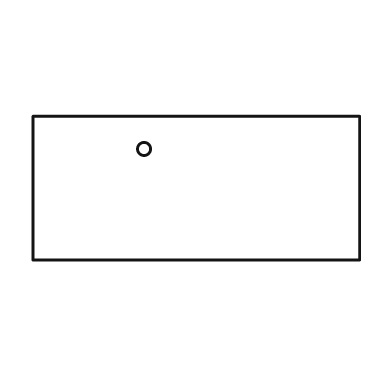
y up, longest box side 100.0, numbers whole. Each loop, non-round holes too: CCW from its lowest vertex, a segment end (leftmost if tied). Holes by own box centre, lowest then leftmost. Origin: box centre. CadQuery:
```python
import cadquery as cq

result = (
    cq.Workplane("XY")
    .moveTo(-50.0, -22.0)
    .lineTo(50.0, -22.0)
    .lineTo(50.0, 22.0)
    .lineTo(-50.0, 22.0)
    .close()
    .moveTo(-16.0, 12.0)
    .circle(2.0)
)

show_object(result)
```